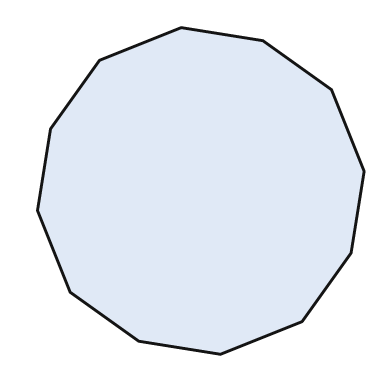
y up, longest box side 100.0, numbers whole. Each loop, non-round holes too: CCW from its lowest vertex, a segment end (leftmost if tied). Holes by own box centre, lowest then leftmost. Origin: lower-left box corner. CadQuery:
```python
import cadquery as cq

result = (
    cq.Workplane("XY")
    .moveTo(56.0, 0.0)
    .lineTo(81.0, 10.0)
    .lineTo(96.0, 31.0)
    .lineTo(100.0, 56.0)
    .lineTo(90.0, 81.0)
    .lineTo(69.0, 96.0)
    .lineTo(44.0, 100.0)
    .lineTo(19.0, 90.0)
    .lineTo(4.0, 69.0)
    .lineTo(0.0, 44.0)
    .lineTo(10.0, 19.0)
    .lineTo(31.0, 4.0)
    .close()
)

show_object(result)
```